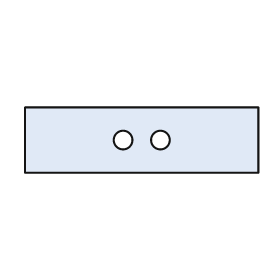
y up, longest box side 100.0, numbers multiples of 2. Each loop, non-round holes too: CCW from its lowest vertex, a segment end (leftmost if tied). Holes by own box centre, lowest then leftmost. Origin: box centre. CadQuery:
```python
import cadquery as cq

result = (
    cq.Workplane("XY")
    .moveTo(-50.0, -14.0)
    .lineTo(50.0, -14.0)
    .lineTo(50.0, 14.0)
    .lineTo(-50.0, 14.0)
    .close()
    .moveTo(-8.0, 0.0)
    .circle(4.0)
    .moveTo(8.0, 0.0)
    .circle(4.0)
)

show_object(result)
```